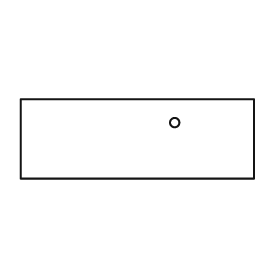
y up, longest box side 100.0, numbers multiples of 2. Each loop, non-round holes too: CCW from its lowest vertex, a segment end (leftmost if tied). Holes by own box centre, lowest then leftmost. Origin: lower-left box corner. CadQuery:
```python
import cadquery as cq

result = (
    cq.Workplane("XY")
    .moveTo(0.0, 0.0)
    .lineTo(100.0, 0.0)
    .lineTo(100.0, 34.0)
    .lineTo(0.0, 34.0)
    .close()
    .moveTo(66.0, 24.0)
    .circle(2.0)
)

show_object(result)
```